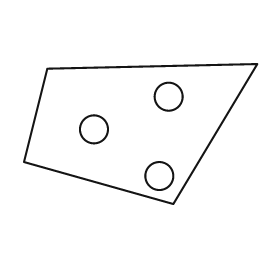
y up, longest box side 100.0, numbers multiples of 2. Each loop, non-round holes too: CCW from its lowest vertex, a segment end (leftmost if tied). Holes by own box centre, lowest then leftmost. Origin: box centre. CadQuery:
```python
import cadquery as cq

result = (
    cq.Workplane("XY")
    .moveTo(14.0, -30.0)
    .lineTo(50.0, 30.0)
    .lineTo(-40.0, 28.0)
    .lineTo(-50.0, -12.0)
    .close()
    .moveTo(8.0, -18.0)
    .circle(6.0)
    .moveTo(-20.0, 2.0)
    .circle(6.0)
    .moveTo(12.0, 16.0)
    .circle(6.0)
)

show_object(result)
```